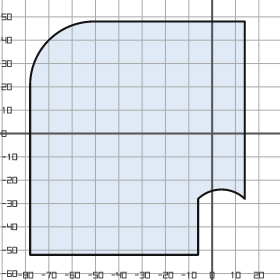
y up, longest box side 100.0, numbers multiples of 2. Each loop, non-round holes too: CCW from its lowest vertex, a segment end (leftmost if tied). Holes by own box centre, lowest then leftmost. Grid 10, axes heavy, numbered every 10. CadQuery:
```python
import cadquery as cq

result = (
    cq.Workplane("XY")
    .moveTo(-78.0, -52.0)
    .lineTo(-6.0, -52.0)
    .lineTo(-6.0, -28.0)
    .threePointArc((4.0, -24.0), (14.0, -28.0))
    .lineTo(14.0, 48.0)
    .lineTo(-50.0, 48.0)
    .threePointArc((-70.0, 40.0), (-78.0, 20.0))
    .close()
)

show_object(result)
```